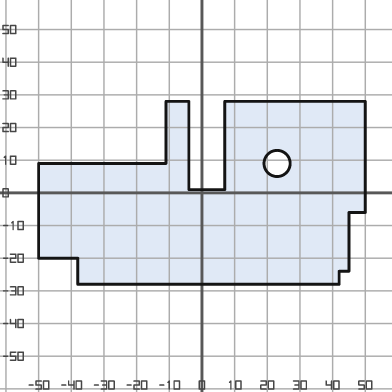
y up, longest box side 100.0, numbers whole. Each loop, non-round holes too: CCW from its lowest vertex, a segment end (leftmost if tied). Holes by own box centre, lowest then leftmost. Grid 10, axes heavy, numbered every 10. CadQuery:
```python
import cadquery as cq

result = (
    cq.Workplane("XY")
    .moveTo(-38.0, -28.0)
    .lineTo(42.0, -28.0)
    .lineTo(42.0, -24.0)
    .lineTo(45.0, -24.0)
    .lineTo(45.0, -6.0)
    .lineTo(50.0, -6.0)
    .lineTo(50.0, 28.0)
    .lineTo(7.0, 28.0)
    .lineTo(7.0, 1.0)
    .lineTo(-4.0, 1.0)
    .lineTo(-4.0, 28.0)
    .lineTo(-11.0, 28.0)
    .lineTo(-11.0, 9.0)
    .lineTo(-50.0, 9.0)
    .lineTo(-50.0, -20.0)
    .lineTo(-38.0, -20.0)
    .close()
    .moveTo(23.0, 9.0)
    .circle(4.0)
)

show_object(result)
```